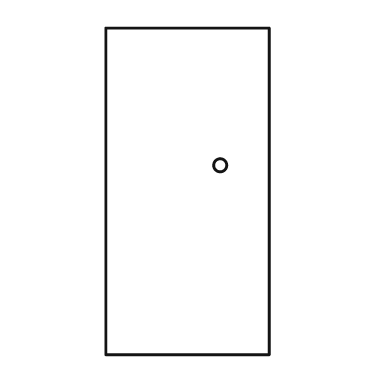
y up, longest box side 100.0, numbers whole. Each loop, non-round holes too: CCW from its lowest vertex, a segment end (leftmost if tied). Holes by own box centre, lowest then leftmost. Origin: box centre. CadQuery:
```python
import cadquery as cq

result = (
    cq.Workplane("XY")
    .moveTo(-25.0, -50.0)
    .lineTo(25.0, -50.0)
    .lineTo(25.0, 50.0)
    .lineTo(-25.0, 50.0)
    .close()
    .moveTo(10.0, 8.0)
    .circle(2.0)
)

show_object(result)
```